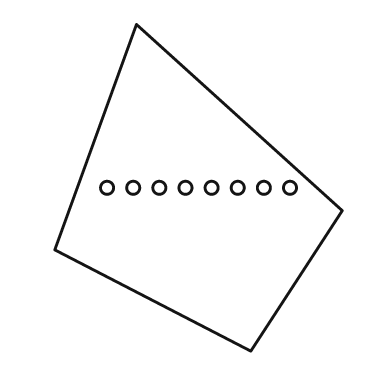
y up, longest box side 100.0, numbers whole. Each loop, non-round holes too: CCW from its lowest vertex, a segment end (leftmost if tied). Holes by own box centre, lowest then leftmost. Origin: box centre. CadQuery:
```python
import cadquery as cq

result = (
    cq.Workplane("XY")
    .moveTo(16.0, -50.0)
    .lineTo(44.0, -7.0)
    .lineTo(-19.0, 50.0)
    .lineTo(-44.0, -19.0)
    .close()
    .moveTo(-28.0, 0.0)
    .circle(2.0)
    .moveTo(-20.0, 0.0)
    .circle(2.0)
    .moveTo(-12.0, 0.0)
    .circle(2.0)
    .moveTo(-4.0, 0.0)
    .circle(2.0)
    .moveTo(4.0, 0.0)
    .circle(2.0)
    .moveTo(12.0, 0.0)
    .circle(2.0)
    .moveTo(20.0, 0.0)
    .circle(2.0)
    .moveTo(28.0, 0.0)
    .circle(2.0)
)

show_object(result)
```